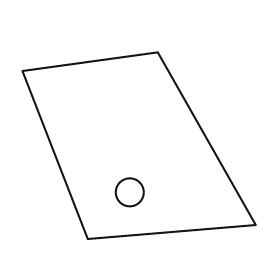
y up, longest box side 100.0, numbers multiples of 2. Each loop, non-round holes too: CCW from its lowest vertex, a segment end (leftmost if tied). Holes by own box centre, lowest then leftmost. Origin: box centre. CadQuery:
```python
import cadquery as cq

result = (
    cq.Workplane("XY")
    .moveTo(-22.0, -40.0)
    .lineTo(50.0, -34.0)
    .lineTo(8.0, 40.0)
    .lineTo(-50.0, 32.0)
    .close()
    .moveTo(-4.0, -20.0)
    .circle(6.0)
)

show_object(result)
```